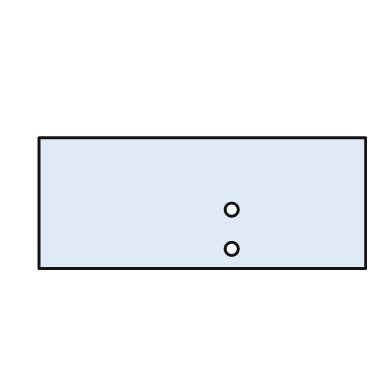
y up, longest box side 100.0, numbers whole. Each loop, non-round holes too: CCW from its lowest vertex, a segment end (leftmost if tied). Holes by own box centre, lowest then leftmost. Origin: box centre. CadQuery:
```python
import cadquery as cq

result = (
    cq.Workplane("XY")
    .moveTo(-50.0, -20.0)
    .lineTo(50.0, -20.0)
    .lineTo(50.0, 20.0)
    .lineTo(-50.0, 20.0)
    .close()
    .moveTo(9.0, -14.0)
    .circle(2.0)
    .moveTo(9.0, -2.0)
    .circle(2.0)
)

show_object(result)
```